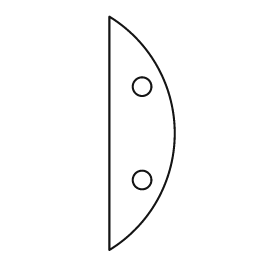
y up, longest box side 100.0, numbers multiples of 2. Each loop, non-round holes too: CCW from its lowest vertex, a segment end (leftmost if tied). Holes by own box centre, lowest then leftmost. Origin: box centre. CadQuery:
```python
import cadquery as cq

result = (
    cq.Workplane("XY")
    .moveTo(-14.0, -50.0)
    .threePointArc((14.0, 0.0), (-14.0, 50.0))
    .close()
    .moveTo(0.0, -20.0)
    .circle(4.0)
    .moveTo(0.0, 20.0)
    .circle(4.0)
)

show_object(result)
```